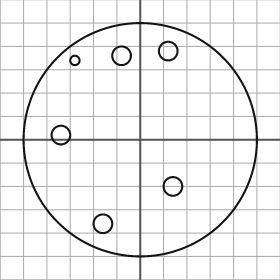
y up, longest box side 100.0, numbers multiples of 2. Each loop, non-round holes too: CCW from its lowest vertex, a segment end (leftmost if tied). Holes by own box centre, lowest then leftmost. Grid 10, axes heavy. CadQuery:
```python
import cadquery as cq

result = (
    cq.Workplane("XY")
    .moveTo(0.0, 0.0)
    .circle(50.0)
    .moveTo(-16.0, -36.0)
    .circle(4.0)
    .moveTo(14.0, -20.0)
    .circle(4.0)
    .moveTo(-34.0, 2.0)
    .circle(4.0)
    .moveTo(-28.0, 34.0)
    .circle(2.0)
    .moveTo(-8.0, 36.0)
    .circle(4.0)
    .moveTo(12.0, 38.0)
    .circle(4.0)
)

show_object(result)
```